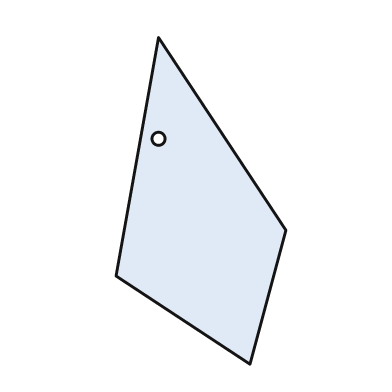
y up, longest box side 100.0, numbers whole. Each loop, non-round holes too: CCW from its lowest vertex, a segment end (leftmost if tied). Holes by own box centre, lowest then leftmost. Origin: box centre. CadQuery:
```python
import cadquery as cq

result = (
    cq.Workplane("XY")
    .moveTo(15.0, -50.0)
    .lineTo(26.0, -9.0)
    .lineTo(-13.0, 50.0)
    .lineTo(-26.0, -23.0)
    .close()
    .moveTo(-13.0, 19.0)
    .circle(2.0)
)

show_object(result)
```